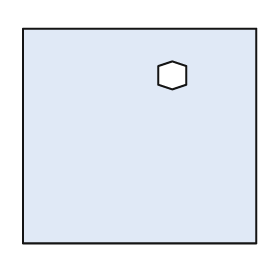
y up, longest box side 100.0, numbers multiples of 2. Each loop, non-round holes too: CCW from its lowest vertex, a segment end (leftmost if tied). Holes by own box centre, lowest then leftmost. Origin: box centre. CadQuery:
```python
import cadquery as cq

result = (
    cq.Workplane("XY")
    .moveTo(-50.0, -46.0)
    .lineTo(50.0, -46.0)
    .lineTo(50.0, 46.0)
    .lineTo(-50.0, 46.0)
    .close()
    .moveTo(14.0, 20.0)
    .lineTo(20.0, 22.0)
    .lineTo(20.0, 30.0)
    .lineTo(14.0, 32.0)
    .lineTo(8.0, 30.0)
    .lineTo(8.0, 22.0)
    .close()
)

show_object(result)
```